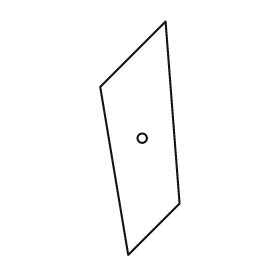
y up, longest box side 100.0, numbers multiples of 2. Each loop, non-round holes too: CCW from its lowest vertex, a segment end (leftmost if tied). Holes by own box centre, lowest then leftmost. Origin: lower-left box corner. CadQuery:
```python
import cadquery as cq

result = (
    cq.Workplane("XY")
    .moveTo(12.0, 0.0)
    .lineTo(34.0, 22.0)
    .lineTo(28.0, 100.0)
    .lineTo(0.0, 72.0)
    .close()
    .moveTo(18.0, 50.0)
    .circle(2.0)
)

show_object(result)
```